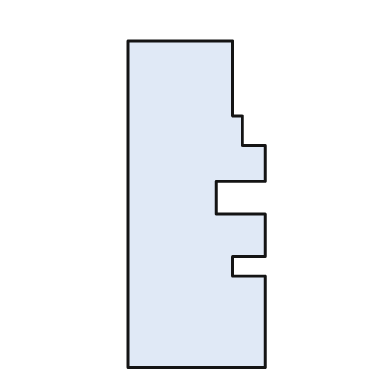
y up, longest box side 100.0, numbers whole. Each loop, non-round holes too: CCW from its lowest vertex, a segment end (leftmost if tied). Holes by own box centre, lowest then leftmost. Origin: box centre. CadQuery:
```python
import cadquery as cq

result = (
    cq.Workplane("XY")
    .moveTo(-21.0, -50.0)
    .lineTo(21.0, -50.0)
    .lineTo(21.0, -22.0)
    .lineTo(11.0, -22.0)
    .lineTo(11.0, -16.0)
    .lineTo(21.0, -16.0)
    .lineTo(21.0, -3.0)
    .lineTo(6.0, -3.0)
    .lineTo(6.0, 7.0)
    .lineTo(21.0, 7.0)
    .lineTo(21.0, 18.0)
    .lineTo(14.0, 18.0)
    .lineTo(14.0, 27.0)
    .lineTo(11.0, 27.0)
    .lineTo(11.0, 50.0)
    .lineTo(-21.0, 50.0)
    .close()
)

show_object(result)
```